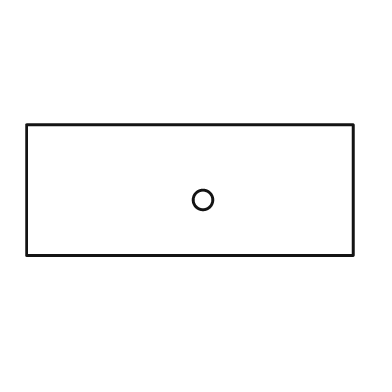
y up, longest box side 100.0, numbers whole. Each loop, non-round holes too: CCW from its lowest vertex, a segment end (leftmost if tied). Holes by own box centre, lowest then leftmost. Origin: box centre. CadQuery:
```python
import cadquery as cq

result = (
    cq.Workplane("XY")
    .moveTo(-50.0, -20.0)
    .lineTo(50.0, -20.0)
    .lineTo(50.0, 20.0)
    .lineTo(-50.0, 20.0)
    .close()
    .moveTo(4.0, -3.0)
    .circle(3.0)
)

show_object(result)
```